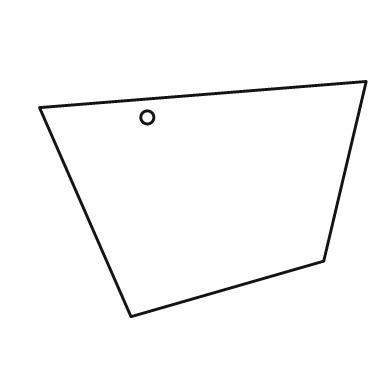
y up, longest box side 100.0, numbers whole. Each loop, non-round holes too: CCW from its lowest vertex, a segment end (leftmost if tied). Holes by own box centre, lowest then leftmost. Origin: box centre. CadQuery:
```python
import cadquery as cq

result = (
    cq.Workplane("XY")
    .moveTo(-22.0, -36.0)
    .lineTo(37.0, -19.0)
    .lineTo(50.0, 36.0)
    .lineTo(-50.0, 28.0)
    .close()
    .moveTo(-17.0, 25.0)
    .circle(2.0)
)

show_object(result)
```